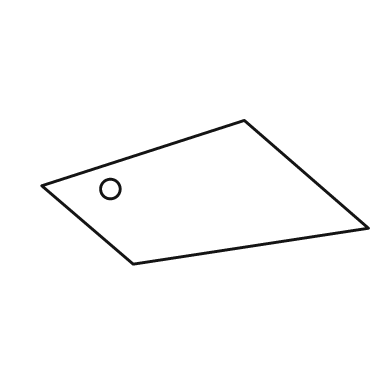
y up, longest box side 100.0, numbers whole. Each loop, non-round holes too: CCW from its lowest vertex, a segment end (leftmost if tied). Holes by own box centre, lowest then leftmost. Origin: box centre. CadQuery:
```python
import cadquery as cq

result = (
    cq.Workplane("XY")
    .moveTo(-22.0, -22.0)
    .lineTo(50.0, -11.0)
    .lineTo(12.0, 22.0)
    .lineTo(-50.0, 2.0)
    .close()
    .moveTo(-29.0, 1.0)
    .circle(3.0)
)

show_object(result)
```